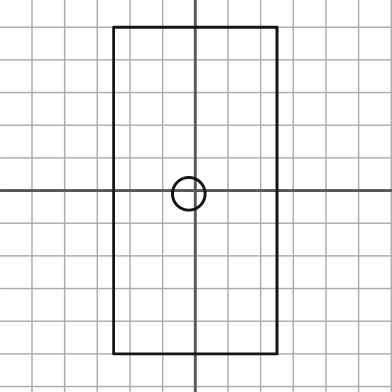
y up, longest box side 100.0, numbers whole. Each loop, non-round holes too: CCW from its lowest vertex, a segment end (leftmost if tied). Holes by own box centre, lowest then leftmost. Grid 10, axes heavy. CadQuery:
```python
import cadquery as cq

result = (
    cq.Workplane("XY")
    .moveTo(-25.0, -50.0)
    .lineTo(25.0, -50.0)
    .lineTo(25.0, 50.0)
    .lineTo(-25.0, 50.0)
    .close()
    .moveTo(-2.0, -1.0)
    .circle(5.0)
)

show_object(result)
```